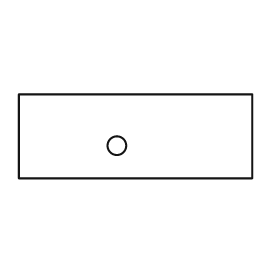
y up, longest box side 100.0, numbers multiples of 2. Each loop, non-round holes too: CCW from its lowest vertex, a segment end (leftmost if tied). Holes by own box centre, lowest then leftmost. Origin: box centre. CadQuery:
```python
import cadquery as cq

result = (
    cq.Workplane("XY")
    .moveTo(-50.0, -18.0)
    .lineTo(50.0, -18.0)
    .lineTo(50.0, 18.0)
    .lineTo(-50.0, 18.0)
    .close()
    .moveTo(-8.0, -4.0)
    .circle(4.0)
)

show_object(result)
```